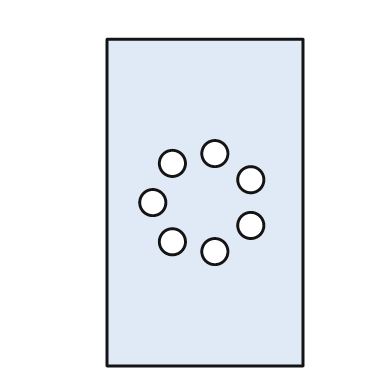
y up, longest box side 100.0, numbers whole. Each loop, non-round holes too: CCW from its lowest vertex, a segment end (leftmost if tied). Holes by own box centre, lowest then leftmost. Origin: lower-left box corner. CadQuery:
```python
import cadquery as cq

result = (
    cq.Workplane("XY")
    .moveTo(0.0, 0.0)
    .lineTo(60.0, 0.0)
    .lineTo(60.0, 100.0)
    .lineTo(0.0, 100.0)
    .close()
    .moveTo(33.0, 35.0)
    .circle(4.0)
    .moveTo(20.0, 38.0)
    .circle(4.0)
    .moveTo(44.0, 43.0)
    .circle(4.0)
    .moveTo(14.0, 50.0)
    .circle(4.0)
    .moveTo(44.0, 57.0)
    .circle(4.0)
    .moveTo(20.0, 62.0)
    .circle(4.0)
    .moveTo(33.0, 65.0)
    .circle(4.0)
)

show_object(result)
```